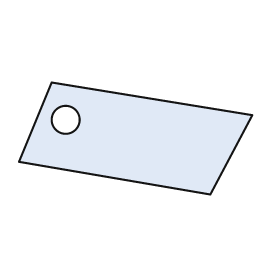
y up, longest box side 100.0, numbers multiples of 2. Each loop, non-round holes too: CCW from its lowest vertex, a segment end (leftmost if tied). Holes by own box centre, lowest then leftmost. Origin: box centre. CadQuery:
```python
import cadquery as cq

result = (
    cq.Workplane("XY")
    .moveTo(32.0, -24.0)
    .lineTo(50.0, 10.0)
    .lineTo(-36.0, 24.0)
    .lineTo(-50.0, -10.0)
    .close()
    .moveTo(-30.0, 8.0)
    .circle(6.0)
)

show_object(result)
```